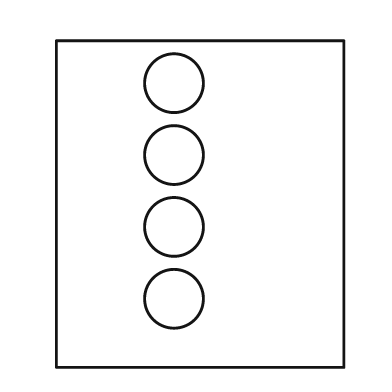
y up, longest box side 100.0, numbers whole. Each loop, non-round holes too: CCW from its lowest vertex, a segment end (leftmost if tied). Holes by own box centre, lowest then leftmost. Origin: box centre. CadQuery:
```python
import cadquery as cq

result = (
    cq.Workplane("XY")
    .moveTo(-44.0, -50.0)
    .lineTo(44.0, -50.0)
    .lineTo(44.0, 50.0)
    .lineTo(-44.0, 50.0)
    .close()
    .moveTo(-8.0, -29.0)
    .circle(9.0)
    .moveTo(-8.0, -7.0)
    .circle(9.0)
    .moveTo(-8.0, 15.0)
    .circle(9.0)
    .moveTo(-8.0, 37.0)
    .circle(9.0)
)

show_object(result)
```